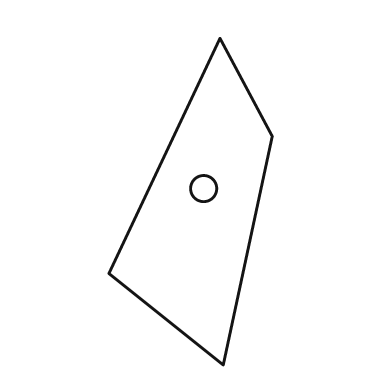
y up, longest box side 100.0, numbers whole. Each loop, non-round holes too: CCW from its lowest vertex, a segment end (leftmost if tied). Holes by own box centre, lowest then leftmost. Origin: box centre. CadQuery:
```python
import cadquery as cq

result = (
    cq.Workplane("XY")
    .moveTo(10.0, -50.0)
    .lineTo(25.0, 20.0)
    .lineTo(9.0, 50.0)
    .lineTo(-25.0, -22.0)
    .close()
    .moveTo(4.0, 4.0)
    .circle(4.0)
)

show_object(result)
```